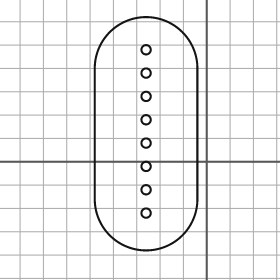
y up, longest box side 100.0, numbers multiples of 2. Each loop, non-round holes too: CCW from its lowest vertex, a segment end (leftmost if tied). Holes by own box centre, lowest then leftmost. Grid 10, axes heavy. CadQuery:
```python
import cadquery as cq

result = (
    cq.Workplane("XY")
    .moveTo(-48.0, -16.0)
    .threePointArc((-26.0, -38.0), (-4.0, -16.0))
    .lineTo(-4.0, 40.0)
    .threePointArc((-26.0, 62.0), (-48.0, 40.0))
    .close()
    .moveTo(-26.0, -22.0)
    .circle(2.0)
    .moveTo(-26.0, -12.0)
    .circle(2.0)
    .moveTo(-26.0, -2.0)
    .circle(2.0)
    .moveTo(-26.0, 8.0)
    .circle(2.0)
    .moveTo(-26.0, 18.0)
    .circle(2.0)
    .moveTo(-26.0, 28.0)
    .circle(2.0)
    .moveTo(-26.0, 38.0)
    .circle(2.0)
    .moveTo(-26.0, 48.0)
    .circle(2.0)
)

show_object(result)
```